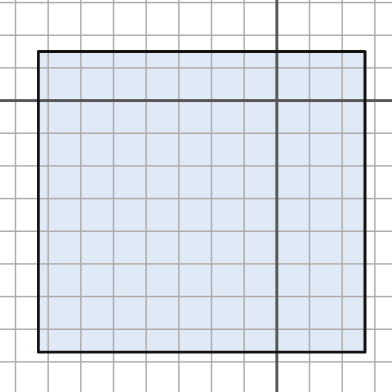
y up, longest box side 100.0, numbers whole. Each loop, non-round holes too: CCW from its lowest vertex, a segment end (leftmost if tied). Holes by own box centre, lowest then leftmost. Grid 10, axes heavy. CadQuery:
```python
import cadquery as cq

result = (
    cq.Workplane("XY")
    .moveTo(-73.0, -77.0)
    .lineTo(27.0, -77.0)
    .lineTo(27.0, 15.0)
    .lineTo(-73.0, 15.0)
    .close()
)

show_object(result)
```